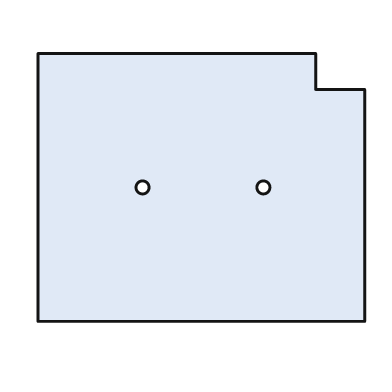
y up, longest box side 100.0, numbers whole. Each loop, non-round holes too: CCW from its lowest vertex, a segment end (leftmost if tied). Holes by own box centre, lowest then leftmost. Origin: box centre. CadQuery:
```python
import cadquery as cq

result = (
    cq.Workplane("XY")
    .moveTo(-50.0, -41.0)
    .lineTo(50.0, -41.0)
    .lineTo(50.0, 30.0)
    .lineTo(35.0, 30.0)
    .lineTo(35.0, 41.0)
    .lineTo(-50.0, 41.0)
    .close()
    .moveTo(-18.0, 0.0)
    .circle(2.0)
    .moveTo(19.0, 0.0)
    .circle(2.0)
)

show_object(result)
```